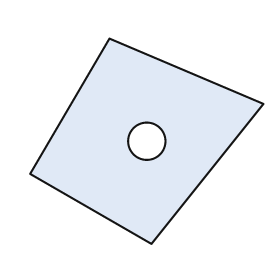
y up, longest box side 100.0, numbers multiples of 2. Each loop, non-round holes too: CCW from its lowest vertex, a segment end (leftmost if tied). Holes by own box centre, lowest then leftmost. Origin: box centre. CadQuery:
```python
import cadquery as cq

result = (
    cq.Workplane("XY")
    .moveTo(2.0, -44.0)
    .lineTo(50.0, 16.0)
    .lineTo(-16.0, 44.0)
    .lineTo(-50.0, -14.0)
    .close()
    .moveTo(0.0, 0.0)
    .circle(8.0)
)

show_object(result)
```